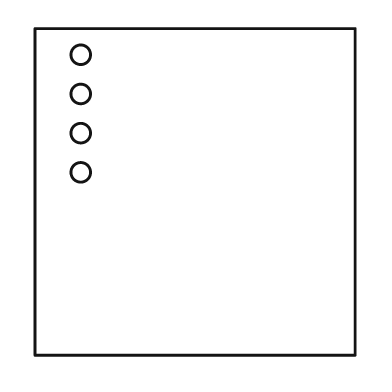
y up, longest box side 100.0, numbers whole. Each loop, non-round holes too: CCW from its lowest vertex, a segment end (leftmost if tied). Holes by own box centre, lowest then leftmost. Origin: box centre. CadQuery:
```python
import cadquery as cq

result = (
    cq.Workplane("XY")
    .moveTo(-49.0, -50.0)
    .lineTo(49.0, -50.0)
    .lineTo(49.0, 50.0)
    .lineTo(-49.0, 50.0)
    .close()
    .moveTo(-35.0, 6.0)
    .circle(3.0)
    .moveTo(-35.0, 18.0)
    .circle(3.0)
    .moveTo(-35.0, 30.0)
    .circle(3.0)
    .moveTo(-35.0, 42.0)
    .circle(3.0)
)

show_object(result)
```